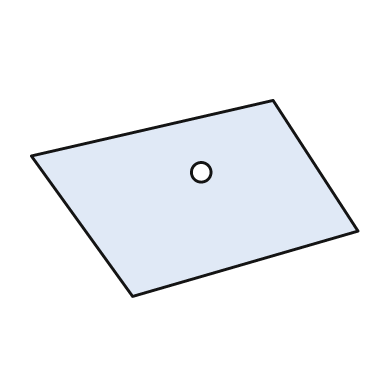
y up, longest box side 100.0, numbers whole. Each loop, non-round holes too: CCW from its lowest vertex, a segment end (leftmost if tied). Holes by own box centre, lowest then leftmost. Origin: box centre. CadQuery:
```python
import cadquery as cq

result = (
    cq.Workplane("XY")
    .moveTo(-19.0, -30.0)
    .lineTo(50.0, -10.0)
    .lineTo(24.0, 30.0)
    .lineTo(-50.0, 13.0)
    .close()
    .moveTo(2.0, 8.0)
    .circle(3.0)
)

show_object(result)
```